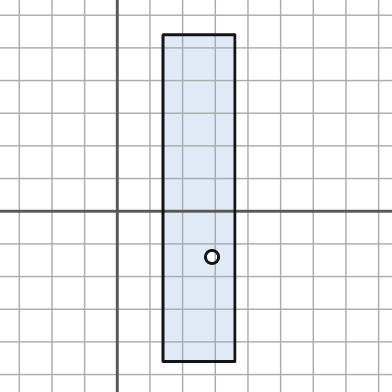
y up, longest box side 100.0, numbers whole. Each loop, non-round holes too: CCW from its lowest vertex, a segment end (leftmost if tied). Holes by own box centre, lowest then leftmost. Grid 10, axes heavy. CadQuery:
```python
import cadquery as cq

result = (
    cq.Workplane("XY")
    .moveTo(14.0, -46.0)
    .lineTo(36.0, -46.0)
    .lineTo(36.0, 54.0)
    .lineTo(14.0, 54.0)
    .close()
    .moveTo(29.0, -14.0)
    .circle(2.0)
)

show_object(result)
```